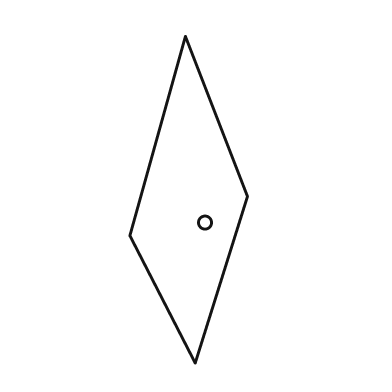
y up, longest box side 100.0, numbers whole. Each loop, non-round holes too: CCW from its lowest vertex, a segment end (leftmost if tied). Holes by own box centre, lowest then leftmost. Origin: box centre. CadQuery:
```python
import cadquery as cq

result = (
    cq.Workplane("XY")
    .moveTo(2.0, -50.0)
    .lineTo(18.0, 1.0)
    .lineTo(-1.0, 50.0)
    .lineTo(-18.0, -11.0)
    .close()
    .moveTo(5.0, -7.0)
    .circle(2.0)
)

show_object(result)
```